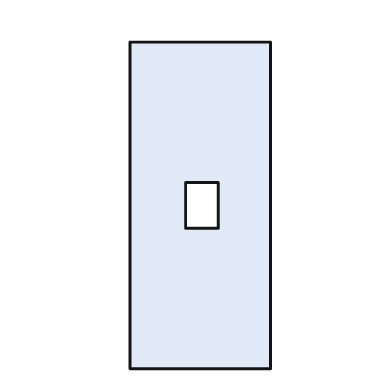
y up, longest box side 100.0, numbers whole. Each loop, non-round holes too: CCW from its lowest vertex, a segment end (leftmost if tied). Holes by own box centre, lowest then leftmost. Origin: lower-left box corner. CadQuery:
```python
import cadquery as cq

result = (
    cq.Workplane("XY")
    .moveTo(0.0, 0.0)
    .lineTo(43.0, 0.0)
    .lineTo(43.0, 100.0)
    .lineTo(0.0, 100.0)
    .close()
    .moveTo(17.0, 43.0)
    .lineTo(27.0, 43.0)
    .lineTo(27.0, 57.0)
    .lineTo(17.0, 57.0)
    .close()
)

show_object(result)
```